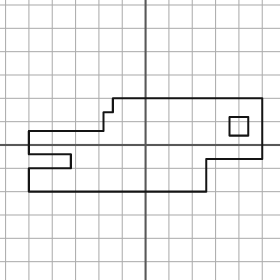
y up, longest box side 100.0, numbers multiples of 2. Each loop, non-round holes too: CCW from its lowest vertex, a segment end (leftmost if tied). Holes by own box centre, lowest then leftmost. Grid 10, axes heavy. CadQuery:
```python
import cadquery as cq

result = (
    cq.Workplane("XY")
    .moveTo(-50.0, -20.0)
    .lineTo(26.0, -20.0)
    .lineTo(26.0, -6.0)
    .lineTo(50.0, -6.0)
    .lineTo(50.0, 20.0)
    .lineTo(-14.0, 20.0)
    .lineTo(-14.0, 14.0)
    .lineTo(-18.0, 14.0)
    .lineTo(-18.0, 6.0)
    .lineTo(-50.0, 6.0)
    .lineTo(-50.0, -4.0)
    .lineTo(-32.0, -4.0)
    .lineTo(-32.0, -10.0)
    .lineTo(-50.0, -10.0)
    .close()
    .moveTo(36.0, 4.0)
    .lineTo(44.0, 4.0)
    .lineTo(44.0, 12.0)
    .lineTo(36.0, 12.0)
    .close()
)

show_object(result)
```